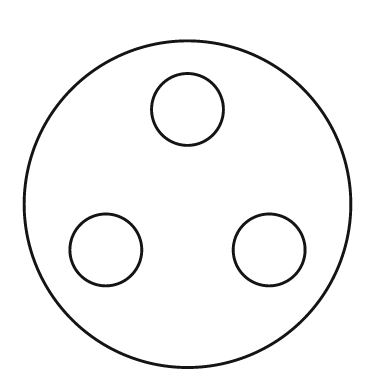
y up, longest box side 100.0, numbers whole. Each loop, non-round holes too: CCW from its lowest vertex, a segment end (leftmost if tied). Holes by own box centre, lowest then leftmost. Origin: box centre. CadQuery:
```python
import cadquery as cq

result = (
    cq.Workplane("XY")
    .moveTo(0.0, 0.0)
    .circle(50.0)
    .moveTo(-25.0, -14.0)
    .circle(11.0)
    .moveTo(25.0, -14.0)
    .circle(11.0)
    .moveTo(0.0, 29.0)
    .circle(11.0)
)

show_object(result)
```